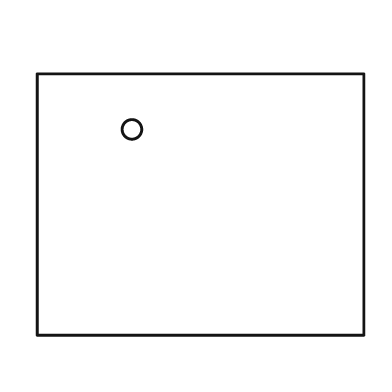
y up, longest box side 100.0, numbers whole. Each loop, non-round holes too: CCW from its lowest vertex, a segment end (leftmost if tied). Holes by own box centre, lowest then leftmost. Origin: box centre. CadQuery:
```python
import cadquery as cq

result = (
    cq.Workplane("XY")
    .moveTo(-50.0, -40.0)
    .lineTo(50.0, -40.0)
    .lineTo(50.0, 40.0)
    .lineTo(-50.0, 40.0)
    .close()
    .moveTo(-21.0, 23.0)
    .circle(3.0)
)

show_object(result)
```